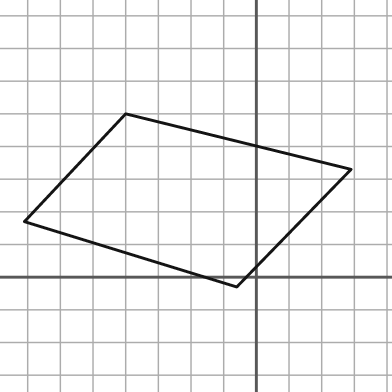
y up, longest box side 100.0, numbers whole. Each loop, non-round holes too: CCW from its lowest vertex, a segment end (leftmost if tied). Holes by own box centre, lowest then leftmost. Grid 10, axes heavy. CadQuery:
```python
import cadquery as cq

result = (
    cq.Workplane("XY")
    .moveTo(-6.0, -3.0)
    .lineTo(29.0, 33.0)
    .lineTo(-40.0, 50.0)
    .lineTo(-71.0, 17.0)
    .close()
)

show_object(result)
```